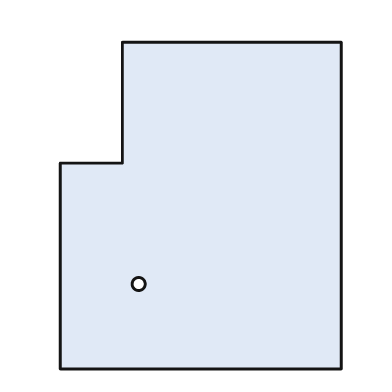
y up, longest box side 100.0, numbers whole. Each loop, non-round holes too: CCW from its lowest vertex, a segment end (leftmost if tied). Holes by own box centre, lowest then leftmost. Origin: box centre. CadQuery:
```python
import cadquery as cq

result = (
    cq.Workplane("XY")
    .moveTo(-43.0, -50.0)
    .lineTo(43.0, -50.0)
    .lineTo(43.0, 50.0)
    .lineTo(-24.0, 50.0)
    .lineTo(-24.0, 13.0)
    .lineTo(-43.0, 13.0)
    .close()
    .moveTo(-19.0, -24.0)
    .circle(2.0)
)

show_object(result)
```